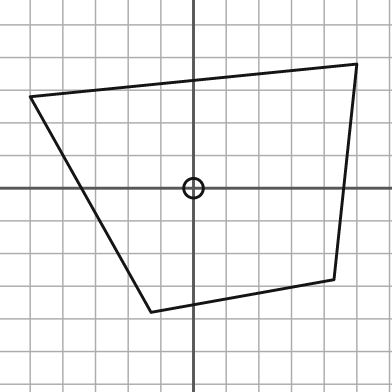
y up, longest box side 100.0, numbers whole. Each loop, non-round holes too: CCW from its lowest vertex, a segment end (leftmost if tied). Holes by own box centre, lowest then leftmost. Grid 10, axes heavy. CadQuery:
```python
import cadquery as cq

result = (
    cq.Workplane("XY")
    .moveTo(-13.0, -38.0)
    .lineTo(43.0, -28.0)
    .lineTo(50.0, 38.0)
    .lineTo(-50.0, 28.0)
    .close()
    .moveTo(0.0, 0.0)
    .circle(3.0)
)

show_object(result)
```